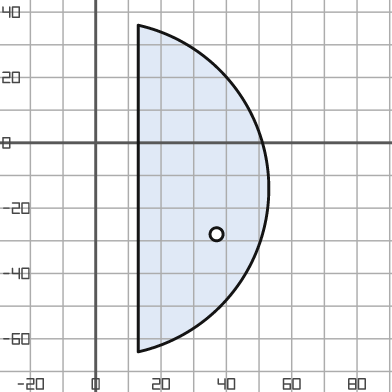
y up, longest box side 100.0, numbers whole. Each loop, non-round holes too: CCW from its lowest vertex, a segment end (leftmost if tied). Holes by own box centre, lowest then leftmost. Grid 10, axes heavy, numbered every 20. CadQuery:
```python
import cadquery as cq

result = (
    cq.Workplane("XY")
    .moveTo(13.0, -64.0)
    .threePointArc((53.0, -14.0), (13.0, 36.0))
    .close()
    .moveTo(37.0, -28.0)
    .circle(2.0)
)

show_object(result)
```